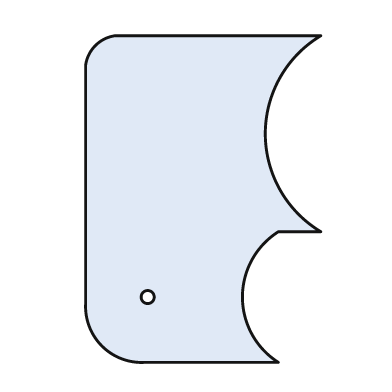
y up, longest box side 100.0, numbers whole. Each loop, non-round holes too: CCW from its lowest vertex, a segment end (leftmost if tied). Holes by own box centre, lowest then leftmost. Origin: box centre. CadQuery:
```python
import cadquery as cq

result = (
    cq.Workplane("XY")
    .moveTo(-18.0, -50.0)
    .lineTo(23.0, -50.0)
    .threePointArc((12.0, -30.0), (23.0, -10.0))
    .lineTo(36.0, -10.0)
    .threePointArc((19.0, 20.0), (36.0, 50.0))
    .lineTo(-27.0, 50.0)
    .threePointArc((-33.0, 47.0), (-36.0, 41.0))
    .lineTo(-36.0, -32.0)
    .threePointArc((-31.0, -45.0), (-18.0, -50.0))
    .close()
    .moveTo(-17.0, -30.0)
    .circle(2.0)
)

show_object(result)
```